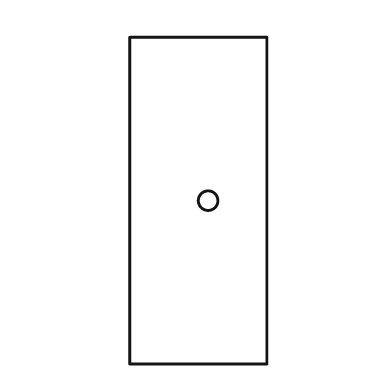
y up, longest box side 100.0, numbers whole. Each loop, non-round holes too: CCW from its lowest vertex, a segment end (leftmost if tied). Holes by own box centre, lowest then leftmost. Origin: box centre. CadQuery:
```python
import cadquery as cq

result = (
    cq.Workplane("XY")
    .moveTo(-21.0, -50.0)
    .lineTo(21.0, -50.0)
    .lineTo(21.0, 50.0)
    .lineTo(-21.0, 50.0)
    .close()
    .moveTo(3.0, 0.0)
    .circle(3.0)
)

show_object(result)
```